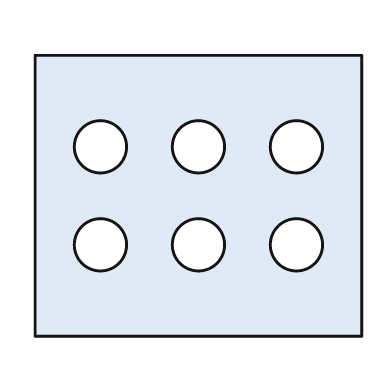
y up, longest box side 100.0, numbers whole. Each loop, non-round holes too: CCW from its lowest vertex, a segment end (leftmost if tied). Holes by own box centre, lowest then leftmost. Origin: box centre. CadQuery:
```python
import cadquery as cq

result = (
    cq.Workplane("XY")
    .moveTo(-50.0, -43.0)
    .lineTo(50.0, -43.0)
    .lineTo(50.0, 43.0)
    .lineTo(-50.0, 43.0)
    .close()
    .moveTo(-30.0, -15.0)
    .circle(8.0)
    .moveTo(0.0, -15.0)
    .circle(8.0)
    .moveTo(30.0, -15.0)
    .circle(8.0)
    .moveTo(-30.0, 15.0)
    .circle(8.0)
    .moveTo(0.0, 15.0)
    .circle(8.0)
    .moveTo(30.0, 15.0)
    .circle(8.0)
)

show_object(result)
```